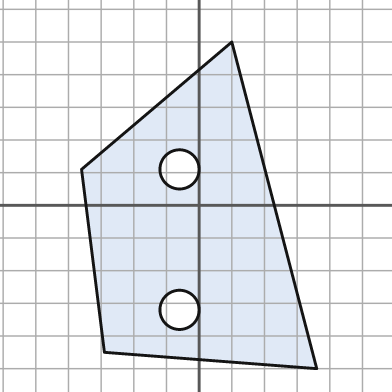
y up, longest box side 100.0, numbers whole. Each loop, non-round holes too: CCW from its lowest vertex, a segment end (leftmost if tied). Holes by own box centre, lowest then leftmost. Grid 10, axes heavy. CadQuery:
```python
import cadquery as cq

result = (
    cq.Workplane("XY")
    .moveTo(36.0, -50.0)
    .lineTo(10.0, 50.0)
    .lineTo(-36.0, 11.0)
    .lineTo(-29.0, -45.0)
    .close()
    .moveTo(-6.0, -32.0)
    .circle(6.0)
    .moveTo(-6.0, 11.0)
    .circle(6.0)
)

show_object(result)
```